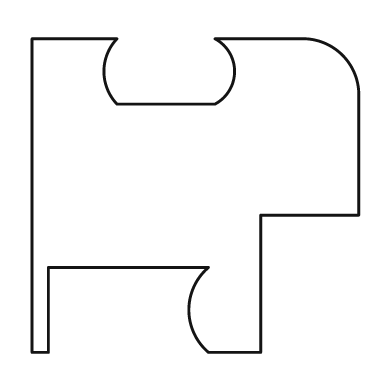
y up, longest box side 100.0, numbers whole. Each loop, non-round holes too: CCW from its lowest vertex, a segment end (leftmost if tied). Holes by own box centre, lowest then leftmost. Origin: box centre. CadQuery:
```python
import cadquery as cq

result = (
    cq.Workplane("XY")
    .moveTo(-50.0, -48.0)
    .lineTo(-45.0, -48.0)
    .lineTo(-45.0, -22.0)
    .lineTo(4.0, -22.0)
    .threePointArc((-2.0, -35.0), (4.0, -48.0))
    .lineTo(20.0, -48.0)
    .lineTo(20.0, -6.0)
    .lineTo(50.0, -6.0)
    .lineTo(50.0, 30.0)
    .threePointArc((45.0, 43.0), (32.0, 48.0))
    .lineTo(6.0, 48.0)
    .threePointArc((12.0, 38.0), (6.0, 28.0))
    .lineTo(-24.0, 28.0)
    .threePointArc((-28.0, 38.0), (-24.0, 48.0))
    .lineTo(-50.0, 48.0)
    .close()
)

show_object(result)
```